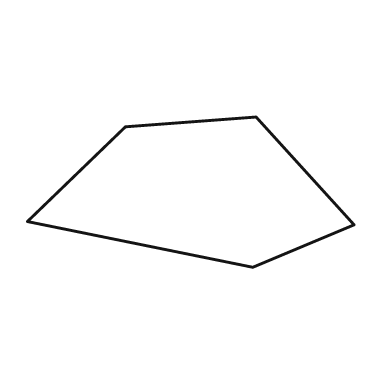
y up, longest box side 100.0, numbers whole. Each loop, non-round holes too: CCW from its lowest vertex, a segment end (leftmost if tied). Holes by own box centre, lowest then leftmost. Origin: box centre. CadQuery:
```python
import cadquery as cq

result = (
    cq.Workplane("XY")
    .moveTo(19.0, -23.0)
    .lineTo(50.0, -10.0)
    .lineTo(20.0, 23.0)
    .lineTo(-20.0, 20.0)
    .lineTo(-50.0, -9.0)
    .close()
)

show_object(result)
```